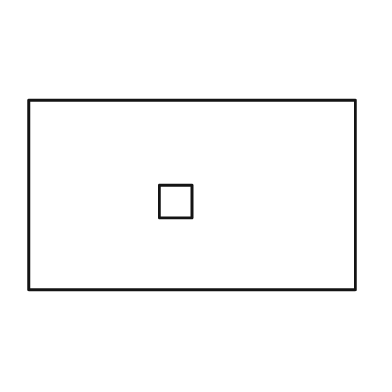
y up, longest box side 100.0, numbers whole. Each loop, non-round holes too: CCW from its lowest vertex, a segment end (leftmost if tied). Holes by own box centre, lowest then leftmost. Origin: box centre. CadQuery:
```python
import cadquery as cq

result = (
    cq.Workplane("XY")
    .moveTo(-50.0, -29.0)
    .lineTo(50.0, -29.0)
    .lineTo(50.0, 29.0)
    .lineTo(-50.0, 29.0)
    .close()
    .moveTo(-10.0, -7.0)
    .lineTo(0.0, -7.0)
    .lineTo(0.0, 3.0)
    .lineTo(-10.0, 3.0)
    .close()
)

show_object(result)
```